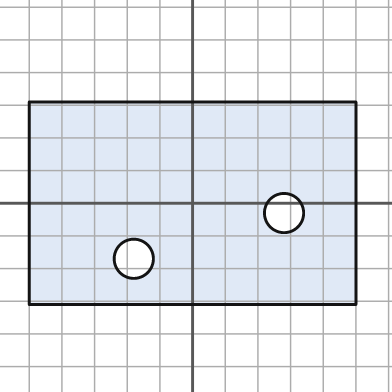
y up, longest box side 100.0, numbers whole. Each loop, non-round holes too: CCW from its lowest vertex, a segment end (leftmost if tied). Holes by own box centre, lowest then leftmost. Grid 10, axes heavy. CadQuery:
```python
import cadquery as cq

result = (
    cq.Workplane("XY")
    .moveTo(-50.0, -31.0)
    .lineTo(50.0, -31.0)
    .lineTo(50.0, 31.0)
    .lineTo(-50.0, 31.0)
    .close()
    .moveTo(-18.0, -17.0)
    .circle(6.0)
    .moveTo(28.0, -3.0)
    .circle(6.0)
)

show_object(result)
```